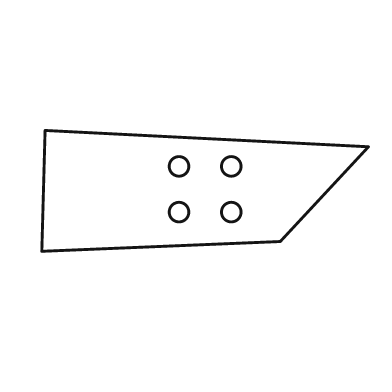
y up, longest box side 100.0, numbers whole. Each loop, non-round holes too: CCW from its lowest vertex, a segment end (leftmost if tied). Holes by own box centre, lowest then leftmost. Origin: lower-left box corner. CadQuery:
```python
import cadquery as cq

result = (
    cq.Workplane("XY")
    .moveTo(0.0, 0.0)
    .lineTo(73.0, 3.0)
    .lineTo(100.0, 32.0)
    .lineTo(1.0, 37.0)
    .close()
    .moveTo(42.0, 12.0)
    .circle(3.0)
    .moveTo(58.0, 12.0)
    .circle(3.0)
    .moveTo(42.0, 26.0)
    .circle(3.0)
    .moveTo(58.0, 26.0)
    .circle(3.0)
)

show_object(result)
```